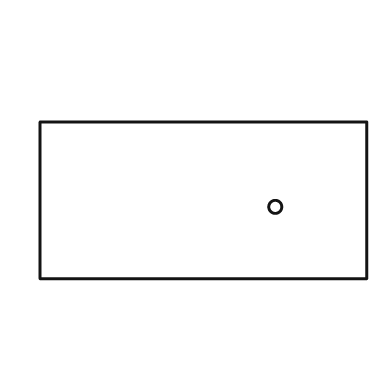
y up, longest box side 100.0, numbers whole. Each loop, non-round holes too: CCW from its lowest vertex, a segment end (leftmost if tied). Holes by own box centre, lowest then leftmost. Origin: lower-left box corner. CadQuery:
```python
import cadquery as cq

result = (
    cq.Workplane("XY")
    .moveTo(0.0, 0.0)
    .lineTo(100.0, 0.0)
    .lineTo(100.0, 48.0)
    .lineTo(0.0, 48.0)
    .close()
    .moveTo(72.0, 22.0)
    .circle(2.0)
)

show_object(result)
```